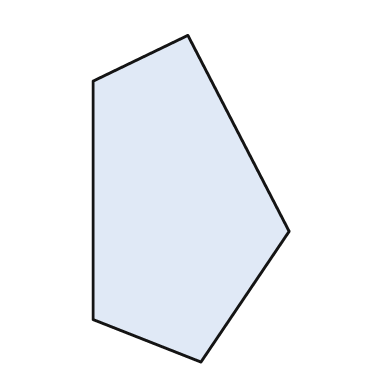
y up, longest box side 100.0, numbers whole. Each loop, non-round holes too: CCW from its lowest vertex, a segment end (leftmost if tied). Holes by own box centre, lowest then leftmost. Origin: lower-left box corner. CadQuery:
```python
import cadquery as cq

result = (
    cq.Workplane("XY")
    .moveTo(33.0, 0.0)
    .lineTo(60.0, 40.0)
    .lineTo(29.0, 100.0)
    .lineTo(0.0, 86.0)
    .lineTo(0.0, 13.0)
    .close()
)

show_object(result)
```